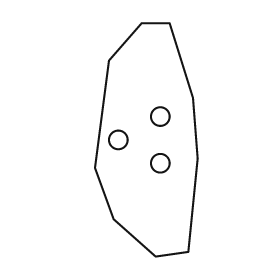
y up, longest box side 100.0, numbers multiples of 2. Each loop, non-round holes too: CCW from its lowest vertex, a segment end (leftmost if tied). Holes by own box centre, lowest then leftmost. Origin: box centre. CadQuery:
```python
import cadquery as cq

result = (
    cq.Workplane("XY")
    .moveTo(4.0, -50.0)
    .lineTo(18.0, -48.0)
    .lineTo(22.0, -8.0)
    .lineTo(20.0, 18.0)
    .lineTo(10.0, 50.0)
    .lineTo(-2.0, 50.0)
    .lineTo(-16.0, 34.0)
    .lineTo(-22.0, -12.0)
    .lineTo(-14.0, -34.0)
    .close()
    .moveTo(6.0, -10.0)
    .circle(4.0)
    .moveTo(-12.0, 0.0)
    .circle(4.0)
    .moveTo(6.0, 10.0)
    .circle(4.0)
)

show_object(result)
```